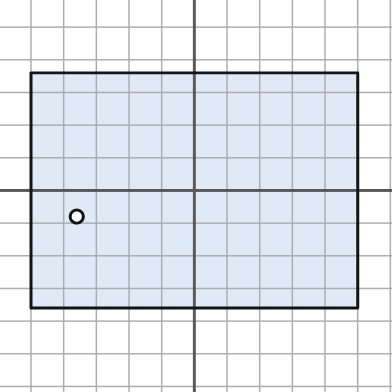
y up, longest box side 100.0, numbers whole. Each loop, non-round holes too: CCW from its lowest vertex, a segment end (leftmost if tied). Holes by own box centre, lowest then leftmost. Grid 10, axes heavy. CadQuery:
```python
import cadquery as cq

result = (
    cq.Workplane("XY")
    .moveTo(-50.0, -36.0)
    .lineTo(50.0, -36.0)
    .lineTo(50.0, 36.0)
    .lineTo(-50.0, 36.0)
    .close()
    .moveTo(-36.0, -8.0)
    .circle(2.0)
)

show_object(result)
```